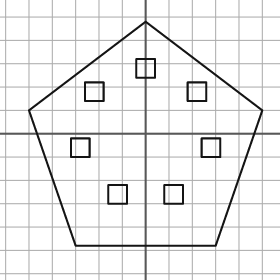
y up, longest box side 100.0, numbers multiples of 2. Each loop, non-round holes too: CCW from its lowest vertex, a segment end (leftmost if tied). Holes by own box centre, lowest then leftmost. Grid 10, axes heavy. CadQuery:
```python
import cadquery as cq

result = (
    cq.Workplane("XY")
    .moveTo(-30.0, -48.0)
    .lineTo(30.0, -48.0)
    .lineTo(50.0, 10.0)
    .lineTo(0.0, 48.0)
    .lineTo(-50.0, 10.0)
    .close()
    .moveTo(-16.0, -30.0)
    .lineTo(-8.0, -30.0)
    .lineTo(-8.0, -22.0)
    .lineTo(-16.0, -22.0)
    .close()
    .moveTo(8.0, -30.0)
    .lineTo(16.0, -30.0)
    .lineTo(16.0, -22.0)
    .lineTo(8.0, -22.0)
    .close()
    .moveTo(-32.0, -10.0)
    .lineTo(-24.0, -10.0)
    .lineTo(-24.0, -2.0)
    .lineTo(-32.0, -2.0)
    .close()
    .moveTo(24.0, -10.0)
    .lineTo(32.0, -10.0)
    .lineTo(32.0, -2.0)
    .lineTo(24.0, -2.0)
    .close()
    .moveTo(-26.0, 14.0)
    .lineTo(-18.0, 14.0)
    .lineTo(-18.0, 22.0)
    .lineTo(-26.0, 22.0)
    .close()
    .moveTo(18.0, 14.0)
    .lineTo(26.0, 14.0)
    .lineTo(26.0, 22.0)
    .lineTo(18.0, 22.0)
    .close()
    .moveTo(-4.0, 24.0)
    .lineTo(4.0, 24.0)
    .lineTo(4.0, 32.0)
    .lineTo(-4.0, 32.0)
    .close()
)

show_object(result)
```